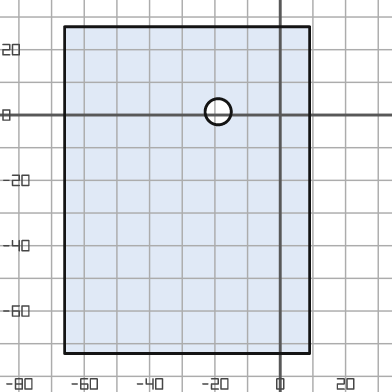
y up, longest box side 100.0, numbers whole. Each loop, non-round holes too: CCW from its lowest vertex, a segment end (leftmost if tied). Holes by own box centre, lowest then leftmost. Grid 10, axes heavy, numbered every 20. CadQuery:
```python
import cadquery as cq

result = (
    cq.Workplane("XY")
    .moveTo(-66.0, -73.0)
    .lineTo(9.0, -73.0)
    .lineTo(9.0, 27.0)
    .lineTo(-66.0, 27.0)
    .close()
    .moveTo(-19.0, 1.0)
    .circle(4.0)
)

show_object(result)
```